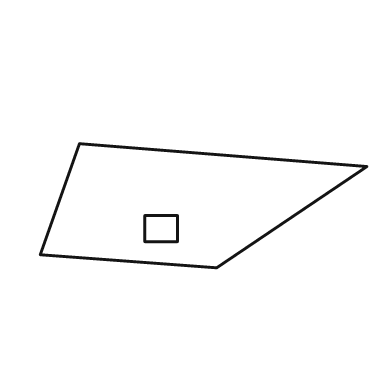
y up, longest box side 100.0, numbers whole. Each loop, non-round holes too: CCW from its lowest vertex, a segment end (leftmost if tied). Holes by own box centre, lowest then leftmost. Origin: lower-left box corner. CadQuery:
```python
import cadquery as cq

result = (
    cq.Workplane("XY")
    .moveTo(54.0, 0.0)
    .lineTo(100.0, 31.0)
    .lineTo(12.0, 38.0)
    .lineTo(0.0, 4.0)
    .close()
    .moveTo(32.0, 8.0)
    .lineTo(42.0, 8.0)
    .lineTo(42.0, 16.0)
    .lineTo(32.0, 16.0)
    .close()
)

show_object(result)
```